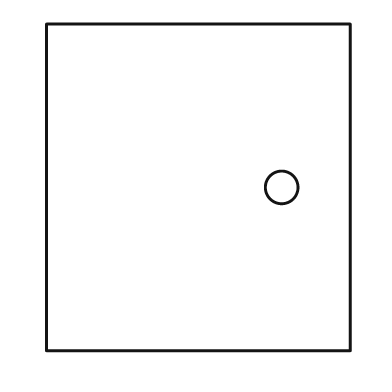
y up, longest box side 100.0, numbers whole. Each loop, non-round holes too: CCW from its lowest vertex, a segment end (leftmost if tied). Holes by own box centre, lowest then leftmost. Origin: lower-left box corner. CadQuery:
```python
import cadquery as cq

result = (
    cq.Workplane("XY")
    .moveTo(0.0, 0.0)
    .lineTo(93.0, 0.0)
    .lineTo(93.0, 100.0)
    .lineTo(0.0, 100.0)
    .close()
    .moveTo(72.0, 50.0)
    .circle(5.0)
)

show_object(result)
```